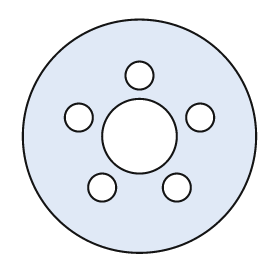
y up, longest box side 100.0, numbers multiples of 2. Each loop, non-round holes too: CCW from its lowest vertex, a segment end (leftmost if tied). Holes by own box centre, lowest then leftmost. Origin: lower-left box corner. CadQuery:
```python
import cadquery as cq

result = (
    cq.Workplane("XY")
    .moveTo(50.0, 50.0)
    .circle(50.0)
    .moveTo(34.0, 28.0)
    .circle(6.0)
    .moveTo(66.0, 28.0)
    .circle(6.0)
    .moveTo(50.0, 50.0)
    .circle(16.0)
    .moveTo(24.0, 58.0)
    .circle(6.0)
    .moveTo(76.0, 58.0)
    .circle(6.0)
    .moveTo(50.0, 76.0)
    .circle(6.0)
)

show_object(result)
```